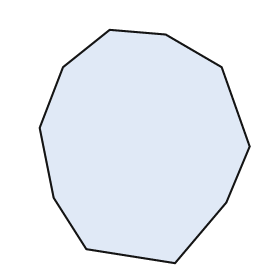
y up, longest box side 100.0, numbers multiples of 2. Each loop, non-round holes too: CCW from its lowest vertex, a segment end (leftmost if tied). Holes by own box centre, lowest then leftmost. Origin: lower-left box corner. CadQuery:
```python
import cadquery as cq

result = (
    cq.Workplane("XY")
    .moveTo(58.0, 0.0)
    .lineTo(80.0, 26.0)
    .lineTo(90.0, 50.0)
    .lineTo(78.0, 84.0)
    .lineTo(54.0, 98.0)
    .lineTo(30.0, 100.0)
    .lineTo(10.0, 84.0)
    .lineTo(0.0, 58.0)
    .lineTo(6.0, 28.0)
    .lineTo(20.0, 6.0)
    .close()
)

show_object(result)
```